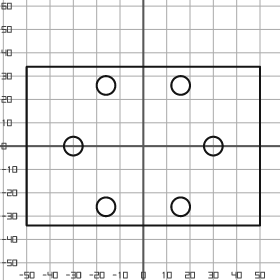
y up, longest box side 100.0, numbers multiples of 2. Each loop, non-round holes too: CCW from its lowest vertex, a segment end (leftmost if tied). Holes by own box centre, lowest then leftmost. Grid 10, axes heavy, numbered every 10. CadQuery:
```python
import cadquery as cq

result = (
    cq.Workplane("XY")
    .moveTo(-50.0, -34.0)
    .lineTo(50.0, -34.0)
    .lineTo(50.0, 34.0)
    .lineTo(-50.0, 34.0)
    .close()
    .moveTo(-16.0, -26.0)
    .circle(4.0)
    .moveTo(16.0, -26.0)
    .circle(4.0)
    .moveTo(-30.0, 0.0)
    .circle(4.0)
    .moveTo(30.0, 0.0)
    .circle(4.0)
    .moveTo(-16.0, 26.0)
    .circle(4.0)
    .moveTo(16.0, 26.0)
    .circle(4.0)
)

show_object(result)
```